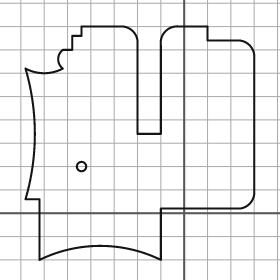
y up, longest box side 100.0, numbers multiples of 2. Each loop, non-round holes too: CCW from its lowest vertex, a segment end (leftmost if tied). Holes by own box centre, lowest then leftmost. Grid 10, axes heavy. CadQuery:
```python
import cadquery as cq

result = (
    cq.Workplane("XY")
    .moveTo(-62.0, -20.0)
    .threePointArc((-36.0, -14.0), (-10.0, -20.0))
    .lineTo(-10.0, 2.0)
    .lineTo(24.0, 2.0)
    .threePointArc((28.0, 4.0), (30.0, 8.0))
    .lineTo(30.0, 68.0)
    .threePointArc((28.0, 72.0), (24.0, 74.0))
    .lineTo(10.0, 74.0)
    .lineTo(10.0, 80.0)
    .lineTo(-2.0, 80.0)
    .threePointArc((-8.0, 78.0), (-10.0, 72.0))
    .lineTo(-10.0, 34.0)
    .lineTo(-20.0, 34.0)
    .lineTo(-20.0, 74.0)
    .threePointArc((-22.0, 78.0), (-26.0, 80.0))
    .lineTo(-44.0, 80.0)
    .lineTo(-44.0, 76.0)
    .lineTo(-48.0, 76.0)
    .lineTo(-48.0, 70.0)
    .lineTo(-52.0, 70.0)
    .threePointArc((-54.0, 66.0), (-52.0, 62.0))
    .threePointArc((-60.0, 60.0), (-68.0, 62.0))
    .threePointArc((-64.0, 34.0), (-68.0, 6.0))
    .lineTo(-62.0, 6.0)
    .close()
    .moveTo(-44.0, 20.0)
    .circle(2.0)
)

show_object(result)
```